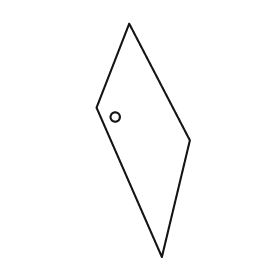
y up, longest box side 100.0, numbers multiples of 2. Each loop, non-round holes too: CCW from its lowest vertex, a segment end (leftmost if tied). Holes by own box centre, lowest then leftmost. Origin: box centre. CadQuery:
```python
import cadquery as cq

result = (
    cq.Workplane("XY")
    .moveTo(8.0, -50.0)
    .lineTo(20.0, 0.0)
    .lineTo(-6.0, 50.0)
    .lineTo(-20.0, 14.0)
    .close()
    .moveTo(-12.0, 10.0)
    .circle(2.0)
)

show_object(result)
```